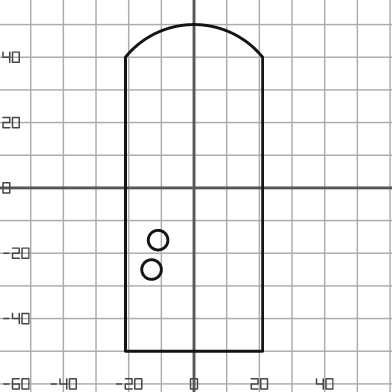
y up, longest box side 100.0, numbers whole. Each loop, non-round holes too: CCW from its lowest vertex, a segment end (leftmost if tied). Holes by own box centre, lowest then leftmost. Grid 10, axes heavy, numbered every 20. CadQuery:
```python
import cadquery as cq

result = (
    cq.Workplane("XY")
    .moveTo(-21.0, -50.0)
    .lineTo(21.0, -50.0)
    .lineTo(21.0, 40.0)
    .threePointArc((0.0, 50.0), (-21.0, 40.0))
    .close()
    .moveTo(-13.0, -25.0)
    .circle(3.0)
    .moveTo(-11.0, -16.0)
    .circle(3.0)
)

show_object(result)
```